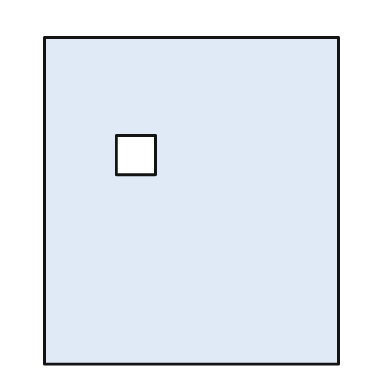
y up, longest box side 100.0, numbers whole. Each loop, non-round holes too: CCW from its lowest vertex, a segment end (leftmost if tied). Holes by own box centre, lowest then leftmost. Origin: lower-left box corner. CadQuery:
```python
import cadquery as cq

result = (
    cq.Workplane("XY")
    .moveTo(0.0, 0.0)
    .lineTo(90.0, 0.0)
    .lineTo(90.0, 100.0)
    .lineTo(0.0, 100.0)
    .close()
    .moveTo(22.0, 58.0)
    .lineTo(34.0, 58.0)
    .lineTo(34.0, 70.0)
    .lineTo(22.0, 70.0)
    .close()
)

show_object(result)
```